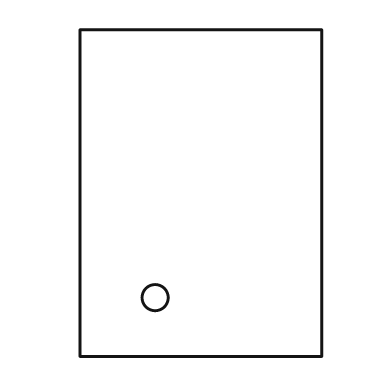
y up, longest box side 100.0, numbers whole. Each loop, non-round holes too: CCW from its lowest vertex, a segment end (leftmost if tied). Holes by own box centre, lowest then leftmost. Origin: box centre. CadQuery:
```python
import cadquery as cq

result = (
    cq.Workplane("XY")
    .moveTo(-37.0, -50.0)
    .lineTo(37.0, -50.0)
    .lineTo(37.0, 50.0)
    .lineTo(-37.0, 50.0)
    .close()
    .moveTo(-14.0, -32.0)
    .circle(4.0)
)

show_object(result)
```